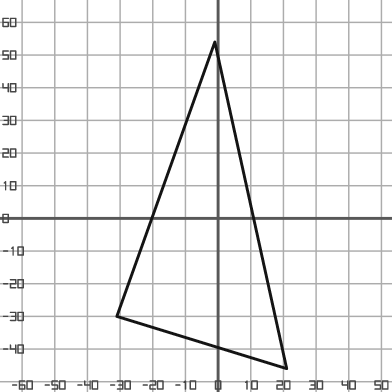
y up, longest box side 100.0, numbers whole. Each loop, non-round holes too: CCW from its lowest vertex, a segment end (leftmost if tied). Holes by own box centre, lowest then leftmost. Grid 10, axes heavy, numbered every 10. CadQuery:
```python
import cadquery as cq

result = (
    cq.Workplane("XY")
    .moveTo(21.0, -46.0)
    .lineTo(-1.0, 54.0)
    .lineTo(-31.0, -30.0)
    .close()
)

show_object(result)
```